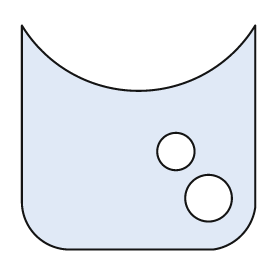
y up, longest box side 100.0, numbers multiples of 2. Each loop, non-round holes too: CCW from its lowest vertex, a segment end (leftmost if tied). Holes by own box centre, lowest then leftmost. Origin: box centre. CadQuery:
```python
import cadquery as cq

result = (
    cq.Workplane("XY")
    .moveTo(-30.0, -48.0)
    .lineTo(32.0, -48.0)
    .threePointArc((44.0, -42.0), (50.0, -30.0))
    .lineTo(50.0, 48.0)
    .threePointArc((0.0, 20.0), (-50.0, 48.0))
    .lineTo(-50.0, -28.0)
    .threePointArc((-44.0, -42.0), (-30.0, -48.0))
    .close()
    .moveTo(30.0, -26.0)
    .circle(10.0)
    .moveTo(16.0, -6.0)
    .circle(8.0)
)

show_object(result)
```